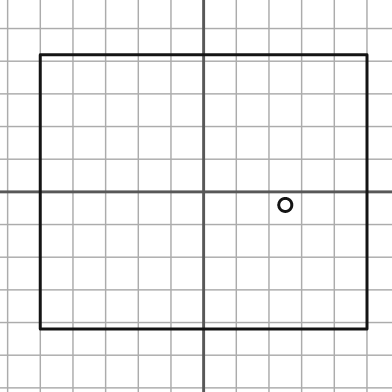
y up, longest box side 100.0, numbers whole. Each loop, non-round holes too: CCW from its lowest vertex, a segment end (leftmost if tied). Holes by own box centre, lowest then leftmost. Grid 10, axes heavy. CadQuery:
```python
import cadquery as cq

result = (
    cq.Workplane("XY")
    .moveTo(-50.0, -42.0)
    .lineTo(50.0, -42.0)
    .lineTo(50.0, 42.0)
    .lineTo(-50.0, 42.0)
    .close()
    .moveTo(25.0, -4.0)
    .circle(2.0)
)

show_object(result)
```